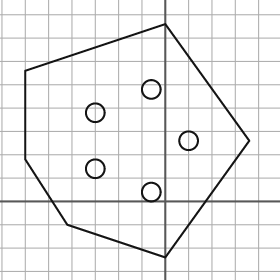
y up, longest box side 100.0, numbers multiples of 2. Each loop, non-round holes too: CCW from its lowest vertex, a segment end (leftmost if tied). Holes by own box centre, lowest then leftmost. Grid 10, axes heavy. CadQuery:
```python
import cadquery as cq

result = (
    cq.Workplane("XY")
    .moveTo(0.0, -24.0)
    .lineTo(36.0, 26.0)
    .lineTo(0.0, 76.0)
    .lineTo(-60.0, 56.0)
    .lineTo(-60.0, 18.0)
    .lineTo(-42.0, -10.0)
    .close()
    .moveTo(-6.0, 4.0)
    .circle(4.0)
    .moveTo(-30.0, 14.0)
    .circle(4.0)
    .moveTo(10.0, 26.0)
    .circle(4.0)
    .moveTo(-30.0, 38.0)
    .circle(4.0)
    .moveTo(-6.0, 48.0)
    .circle(4.0)
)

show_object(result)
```